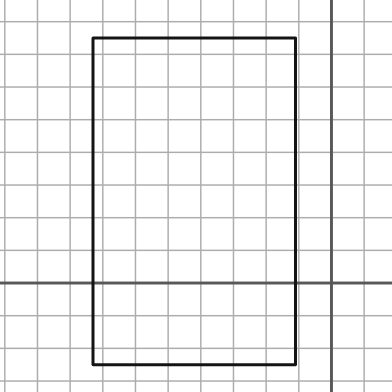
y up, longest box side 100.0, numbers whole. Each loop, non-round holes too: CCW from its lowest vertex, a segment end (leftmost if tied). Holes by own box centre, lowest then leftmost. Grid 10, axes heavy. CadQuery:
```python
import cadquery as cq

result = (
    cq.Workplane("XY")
    .moveTo(-73.0, -25.0)
    .lineTo(-11.0, -25.0)
    .lineTo(-11.0, 75.0)
    .lineTo(-73.0, 75.0)
    .close()
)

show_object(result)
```